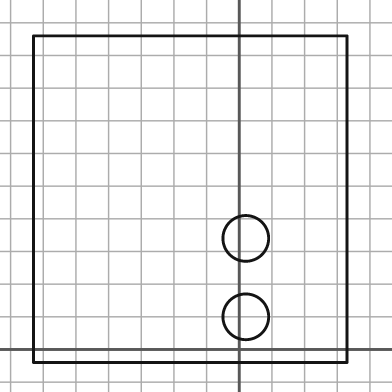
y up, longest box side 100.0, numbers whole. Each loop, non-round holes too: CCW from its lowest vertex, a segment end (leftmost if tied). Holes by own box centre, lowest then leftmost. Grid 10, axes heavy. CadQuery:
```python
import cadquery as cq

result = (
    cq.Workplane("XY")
    .moveTo(-63.0, -4.0)
    .lineTo(33.0, -4.0)
    .lineTo(33.0, 96.0)
    .lineTo(-63.0, 96.0)
    .close()
    .moveTo(2.0, 10.0)
    .circle(7.0)
    .moveTo(2.0, 34.0)
    .circle(7.0)
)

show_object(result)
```